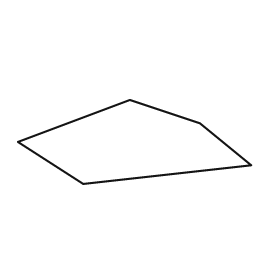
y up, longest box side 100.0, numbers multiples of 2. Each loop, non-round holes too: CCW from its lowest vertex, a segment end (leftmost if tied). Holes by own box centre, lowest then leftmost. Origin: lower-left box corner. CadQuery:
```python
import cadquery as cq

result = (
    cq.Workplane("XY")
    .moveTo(28.0, 0.0)
    .lineTo(100.0, 8.0)
    .lineTo(78.0, 26.0)
    .lineTo(48.0, 36.0)
    .lineTo(0.0, 18.0)
    .close()
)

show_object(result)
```